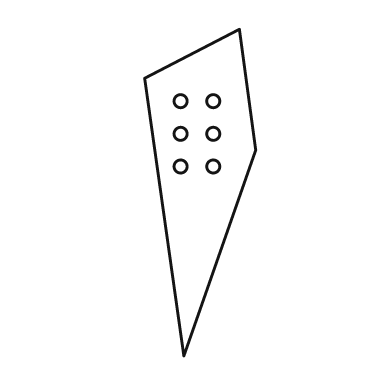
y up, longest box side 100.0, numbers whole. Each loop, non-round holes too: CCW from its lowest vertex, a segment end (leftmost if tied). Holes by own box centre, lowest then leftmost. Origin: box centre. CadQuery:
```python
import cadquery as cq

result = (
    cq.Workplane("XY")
    .moveTo(-5.0, -50.0)
    .lineTo(17.0, 13.0)
    .lineTo(12.0, 50.0)
    .lineTo(-17.0, 35.0)
    .close()
    .moveTo(-6.0, 8.0)
    .circle(2.0)
    .moveTo(4.0, 8.0)
    .circle(2.0)
    .moveTo(-6.0, 18.0)
    .circle(2.0)
    .moveTo(4.0, 18.0)
    .circle(2.0)
    .moveTo(-6.0, 28.0)
    .circle(2.0)
    .moveTo(4.0, 28.0)
    .circle(2.0)
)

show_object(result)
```